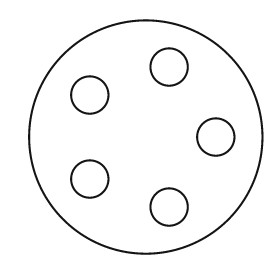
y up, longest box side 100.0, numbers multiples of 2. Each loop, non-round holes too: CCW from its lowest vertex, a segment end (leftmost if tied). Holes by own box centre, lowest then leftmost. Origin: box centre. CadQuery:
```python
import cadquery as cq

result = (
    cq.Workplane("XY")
    .moveTo(0.0, 0.0)
    .circle(50.0)
    .moveTo(10.0, -30.0)
    .circle(8.0)
    .moveTo(-24.0, -18.0)
    .circle(8.0)
    .moveTo(30.0, 0.0)
    .circle(8.0)
    .moveTo(-24.0, 18.0)
    .circle(8.0)
    .moveTo(10.0, 30.0)
    .circle(8.0)
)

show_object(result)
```